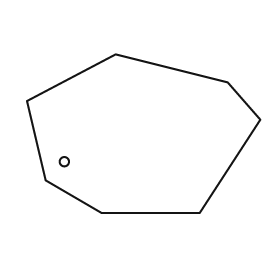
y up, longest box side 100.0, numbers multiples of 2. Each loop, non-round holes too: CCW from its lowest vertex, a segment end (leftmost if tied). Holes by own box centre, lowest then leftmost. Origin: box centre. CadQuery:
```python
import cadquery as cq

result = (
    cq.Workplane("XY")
    .moveTo(-18.0, -34.0)
    .lineTo(24.0, -34.0)
    .lineTo(50.0, 6.0)
    .lineTo(36.0, 22.0)
    .lineTo(-12.0, 34.0)
    .lineTo(-50.0, 14.0)
    .lineTo(-42.0, -20.0)
    .close()
    .moveTo(-34.0, -12.0)
    .circle(2.0)
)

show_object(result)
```